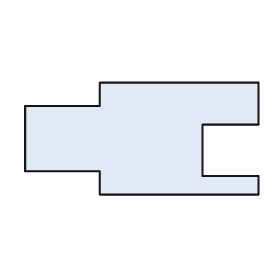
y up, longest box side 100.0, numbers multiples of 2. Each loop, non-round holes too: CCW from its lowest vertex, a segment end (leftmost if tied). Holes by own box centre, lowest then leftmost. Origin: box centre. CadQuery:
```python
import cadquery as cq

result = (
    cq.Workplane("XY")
    .moveTo(-18.0, -24.0)
    .lineTo(50.0, -24.0)
    .lineTo(50.0, -16.0)
    .lineTo(26.0, -16.0)
    .lineTo(26.0, 6.0)
    .lineTo(50.0, 6.0)
    .lineTo(50.0, 24.0)
    .lineTo(-18.0, 24.0)
    .lineTo(-18.0, 14.0)
    .lineTo(-50.0, 14.0)
    .lineTo(-50.0, -14.0)
    .lineTo(-18.0, -14.0)
    .close()
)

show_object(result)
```